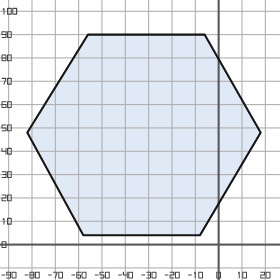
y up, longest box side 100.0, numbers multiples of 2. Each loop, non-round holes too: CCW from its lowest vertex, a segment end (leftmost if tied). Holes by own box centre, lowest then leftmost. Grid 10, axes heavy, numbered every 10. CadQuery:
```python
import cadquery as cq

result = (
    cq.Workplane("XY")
    .moveTo(-58.0, 4.0)
    .lineTo(-8.0, 4.0)
    .lineTo(18.0, 48.0)
    .lineTo(-6.0, 90.0)
    .lineTo(-56.0, 90.0)
    .lineTo(-82.0, 48.0)
    .close()
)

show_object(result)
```